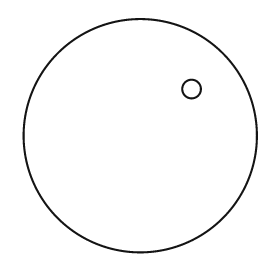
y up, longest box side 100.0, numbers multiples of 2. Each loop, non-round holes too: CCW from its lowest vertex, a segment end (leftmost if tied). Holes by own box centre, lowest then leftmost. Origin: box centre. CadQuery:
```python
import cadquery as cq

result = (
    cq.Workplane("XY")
    .moveTo(0.0, 0.0)
    .circle(50.0)
    .moveTo(22.0, 20.0)
    .circle(4.0)
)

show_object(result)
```